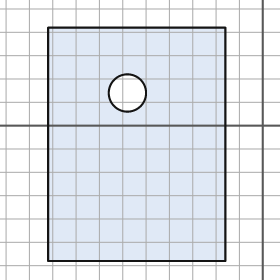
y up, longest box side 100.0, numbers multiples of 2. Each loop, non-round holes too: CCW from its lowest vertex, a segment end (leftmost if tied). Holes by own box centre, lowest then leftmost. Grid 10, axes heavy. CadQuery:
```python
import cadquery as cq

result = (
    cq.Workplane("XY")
    .moveTo(-92.0, -58.0)
    .lineTo(-16.0, -58.0)
    .lineTo(-16.0, 42.0)
    .lineTo(-92.0, 42.0)
    .close()
    .moveTo(-58.0, 14.0)
    .circle(8.0)
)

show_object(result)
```